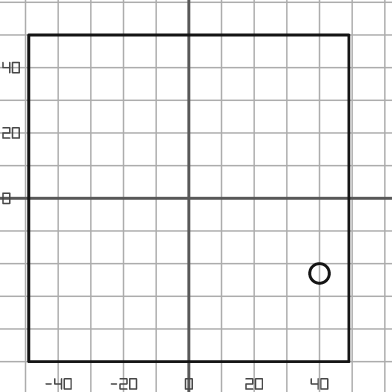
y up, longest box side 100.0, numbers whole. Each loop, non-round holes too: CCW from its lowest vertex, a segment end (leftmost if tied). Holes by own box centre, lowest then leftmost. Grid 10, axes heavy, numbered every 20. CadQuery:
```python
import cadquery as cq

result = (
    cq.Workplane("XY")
    .moveTo(-49.0, -50.0)
    .lineTo(49.0, -50.0)
    .lineTo(49.0, 50.0)
    .lineTo(-49.0, 50.0)
    .close()
    .moveTo(40.0, -23.0)
    .circle(3.0)
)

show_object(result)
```